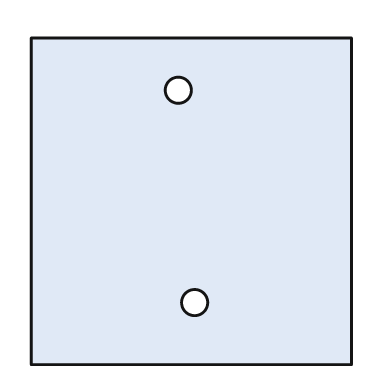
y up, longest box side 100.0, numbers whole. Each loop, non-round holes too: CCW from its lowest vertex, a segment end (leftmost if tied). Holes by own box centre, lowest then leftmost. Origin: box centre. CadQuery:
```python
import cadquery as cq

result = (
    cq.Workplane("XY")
    .moveTo(-49.0, -50.0)
    .lineTo(49.0, -50.0)
    .lineTo(49.0, 50.0)
    .lineTo(-49.0, 50.0)
    .close()
    .moveTo(1.0, -31.0)
    .circle(4.0)
    .moveTo(-4.0, 34.0)
    .circle(4.0)
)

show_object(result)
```